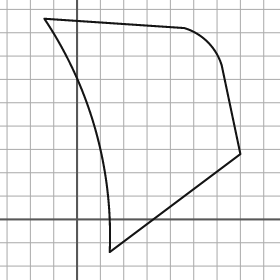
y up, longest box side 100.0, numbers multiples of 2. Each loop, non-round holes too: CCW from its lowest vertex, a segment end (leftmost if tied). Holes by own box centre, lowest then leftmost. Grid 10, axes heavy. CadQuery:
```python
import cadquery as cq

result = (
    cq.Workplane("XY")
    .moveTo(14.0, -14.0)
    .lineTo(70.0, 28.0)
    .lineTo(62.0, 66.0)
    .threePointArc((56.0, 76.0), (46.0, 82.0))
    .lineTo(-14.0, 86.0)
    .threePointArc((8.0, 38.0), (14.0, -14.0))
    .close()
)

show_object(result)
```